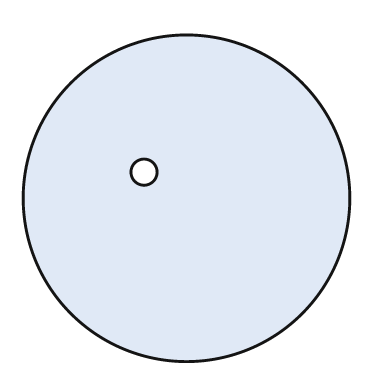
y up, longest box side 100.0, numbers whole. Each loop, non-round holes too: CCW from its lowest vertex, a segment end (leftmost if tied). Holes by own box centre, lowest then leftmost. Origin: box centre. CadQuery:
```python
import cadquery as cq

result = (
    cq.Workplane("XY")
    .moveTo(0.0, 0.0)
    .circle(50.0)
    .moveTo(-13.0, 8.0)
    .circle(4.0)
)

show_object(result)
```